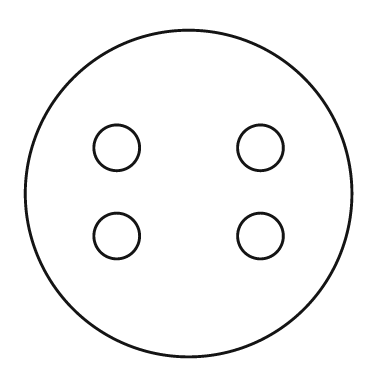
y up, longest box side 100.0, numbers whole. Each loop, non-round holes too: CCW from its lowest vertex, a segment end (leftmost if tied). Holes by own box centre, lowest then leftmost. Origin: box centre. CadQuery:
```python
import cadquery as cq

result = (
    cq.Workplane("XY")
    .moveTo(0.0, 0.0)
    .circle(50.0)
    .moveTo(-22.0, -13.0)
    .circle(7.0)
    .moveTo(22.0, -13.0)
    .circle(7.0)
    .moveTo(-22.0, 14.0)
    .circle(7.0)
    .moveTo(22.0, 14.0)
    .circle(7.0)
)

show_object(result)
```